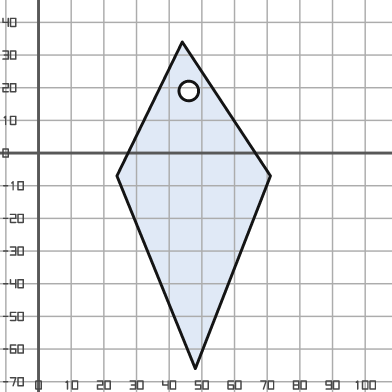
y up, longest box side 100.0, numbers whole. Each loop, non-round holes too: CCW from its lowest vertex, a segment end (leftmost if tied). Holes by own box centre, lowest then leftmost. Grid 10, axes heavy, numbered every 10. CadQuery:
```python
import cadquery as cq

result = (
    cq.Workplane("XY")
    .moveTo(48.0, -66.0)
    .lineTo(71.0, -7.0)
    .lineTo(44.0, 34.0)
    .lineTo(24.0, -7.0)
    .close()
    .moveTo(46.0, 19.0)
    .circle(3.0)
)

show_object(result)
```